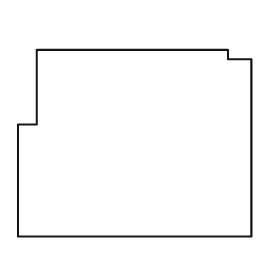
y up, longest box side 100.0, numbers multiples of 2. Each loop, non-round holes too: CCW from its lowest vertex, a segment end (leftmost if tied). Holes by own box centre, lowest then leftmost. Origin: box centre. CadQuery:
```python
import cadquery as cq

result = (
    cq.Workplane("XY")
    .moveTo(-50.0, -40.0)
    .lineTo(50.0, -40.0)
    .lineTo(50.0, 36.0)
    .lineTo(40.0, 36.0)
    .lineTo(40.0, 40.0)
    .lineTo(-42.0, 40.0)
    .lineTo(-42.0, 8.0)
    .lineTo(-50.0, 8.0)
    .close()
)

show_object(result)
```